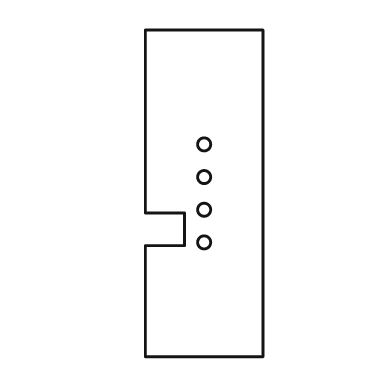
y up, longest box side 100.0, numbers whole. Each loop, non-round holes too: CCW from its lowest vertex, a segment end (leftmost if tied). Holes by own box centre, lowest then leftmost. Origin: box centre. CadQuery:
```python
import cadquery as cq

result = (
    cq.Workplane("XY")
    .moveTo(-18.0, -50.0)
    .lineTo(18.0, -50.0)
    .lineTo(18.0, 50.0)
    .lineTo(-18.0, 50.0)
    .lineTo(-18.0, -6.0)
    .lineTo(-6.0, -6.0)
    .lineTo(-6.0, -16.0)
    .lineTo(-18.0, -16.0)
    .close()
    .moveTo(0.0, -15.0)
    .circle(2.0)
    .moveTo(0.0, -5.0)
    .circle(2.0)
    .moveTo(0.0, 5.0)
    .circle(2.0)
    .moveTo(0.0, 15.0)
    .circle(2.0)
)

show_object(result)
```